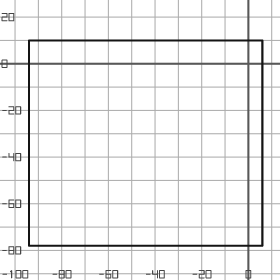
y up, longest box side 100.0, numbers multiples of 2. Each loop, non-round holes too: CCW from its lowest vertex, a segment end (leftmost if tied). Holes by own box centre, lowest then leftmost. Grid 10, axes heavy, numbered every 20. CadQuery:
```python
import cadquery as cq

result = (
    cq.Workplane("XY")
    .moveTo(-94.0, -78.0)
    .lineTo(6.0, -78.0)
    .lineTo(6.0, 10.0)
    .lineTo(-94.0, 10.0)
    .close()
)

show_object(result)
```